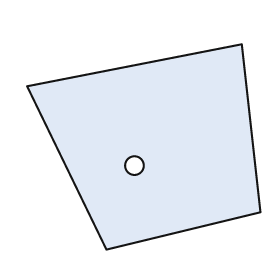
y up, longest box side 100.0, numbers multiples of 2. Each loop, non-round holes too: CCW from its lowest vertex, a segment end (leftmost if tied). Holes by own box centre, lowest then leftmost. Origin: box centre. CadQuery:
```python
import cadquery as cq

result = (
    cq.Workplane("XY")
    .moveTo(-16.0, -44.0)
    .lineTo(50.0, -28.0)
    .lineTo(42.0, 44.0)
    .lineTo(-50.0, 26.0)
    .close()
    .moveTo(-4.0, -8.0)
    .circle(4.0)
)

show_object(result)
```